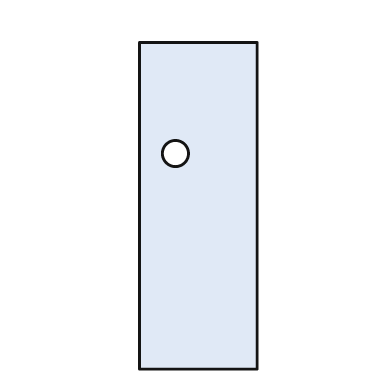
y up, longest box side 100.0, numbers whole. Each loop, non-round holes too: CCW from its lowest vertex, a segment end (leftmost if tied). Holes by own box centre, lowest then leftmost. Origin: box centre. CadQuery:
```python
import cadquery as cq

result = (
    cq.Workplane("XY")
    .moveTo(-18.0, -50.0)
    .lineTo(18.0, -50.0)
    .lineTo(18.0, 50.0)
    .lineTo(-18.0, 50.0)
    .close()
    .moveTo(-7.0, 16.0)
    .circle(4.0)
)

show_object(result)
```